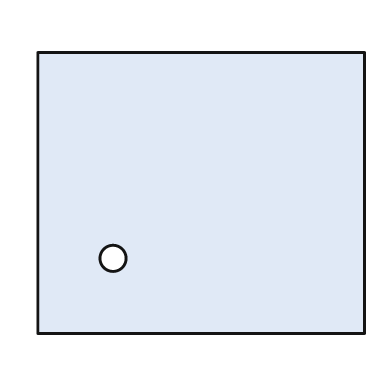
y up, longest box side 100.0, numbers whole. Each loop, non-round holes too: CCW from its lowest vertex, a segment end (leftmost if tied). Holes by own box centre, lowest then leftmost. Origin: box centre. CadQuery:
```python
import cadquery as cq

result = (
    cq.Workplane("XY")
    .moveTo(-50.0, -43.0)
    .lineTo(50.0, -43.0)
    .lineTo(50.0, 43.0)
    .lineTo(-50.0, 43.0)
    .close()
    .moveTo(-27.0, -20.0)
    .circle(4.0)
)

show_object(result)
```